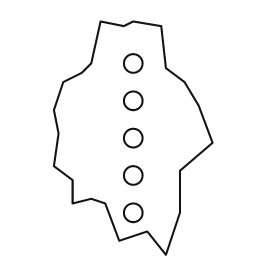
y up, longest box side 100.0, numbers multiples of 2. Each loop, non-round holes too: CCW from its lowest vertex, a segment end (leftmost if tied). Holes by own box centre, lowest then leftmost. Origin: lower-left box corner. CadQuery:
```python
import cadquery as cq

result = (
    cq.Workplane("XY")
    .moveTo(48.0, 0.0)
    .lineTo(54.0, 18.0)
    .lineTo(54.0, 36.0)
    .lineTo(68.0, 48.0)
    .lineTo(62.0, 64.0)
    .lineTo(56.0, 74.0)
    .lineTo(48.0, 80.0)
    .lineTo(46.0, 98.0)
    .lineTo(34.0, 100.0)
    .lineTo(30.0, 98.0)
    .lineTo(20.0, 100.0)
    .lineTo(16.0, 82.0)
    .lineTo(12.0, 78.0)
    .lineTo(4.0, 74.0)
    .lineTo(0.0, 62.0)
    .lineTo(2.0, 52.0)
    .lineTo(0.0, 38.0)
    .lineTo(8.0, 32.0)
    .lineTo(8.0, 22.0)
    .lineTo(16.0, 24.0)
    .lineTo(22.0, 22.0)
    .lineTo(28.0, 6.0)
    .lineTo(40.0, 10.0)
    .close()
    .moveTo(34.0, 18.0)
    .circle(4.0)
    .moveTo(34.0, 34.0)
    .circle(4.0)
    .moveTo(34.0, 50.0)
    .circle(4.0)
    .moveTo(34.0, 66.0)
    .circle(4.0)
    .moveTo(34.0, 82.0)
    .circle(4.0)
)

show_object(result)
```